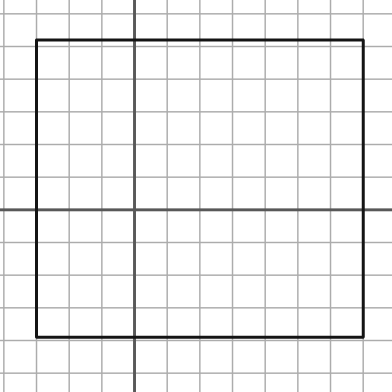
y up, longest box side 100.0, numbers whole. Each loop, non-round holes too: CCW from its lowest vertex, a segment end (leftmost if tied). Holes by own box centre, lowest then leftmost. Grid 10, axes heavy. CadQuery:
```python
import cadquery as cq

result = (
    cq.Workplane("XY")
    .moveTo(-30.0, -39.0)
    .lineTo(70.0, -39.0)
    .lineTo(70.0, 52.0)
    .lineTo(-30.0, 52.0)
    .close()
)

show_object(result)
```